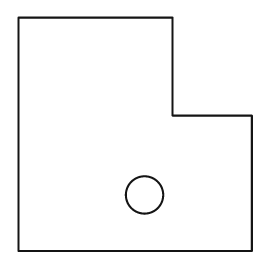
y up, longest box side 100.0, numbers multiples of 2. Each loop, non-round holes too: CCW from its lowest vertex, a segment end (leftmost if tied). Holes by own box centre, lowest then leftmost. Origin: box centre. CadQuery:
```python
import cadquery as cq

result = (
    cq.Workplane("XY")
    .moveTo(-50.0, -50.0)
    .lineTo(50.0, -50.0)
    .lineTo(50.0, 8.0)
    .lineTo(16.0, 8.0)
    .lineTo(16.0, 50.0)
    .lineTo(-50.0, 50.0)
    .close()
    .moveTo(4.0, -26.0)
    .circle(8.0)
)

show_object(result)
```